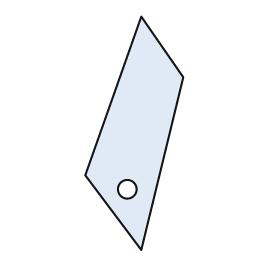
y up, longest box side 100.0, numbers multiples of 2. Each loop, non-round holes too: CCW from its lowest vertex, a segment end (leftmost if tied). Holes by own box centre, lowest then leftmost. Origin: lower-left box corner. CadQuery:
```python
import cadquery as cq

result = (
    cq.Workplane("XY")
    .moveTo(24.0, 0.0)
    .lineTo(42.0, 74.0)
    .lineTo(24.0, 100.0)
    .lineTo(0.0, 32.0)
    .close()
    .moveTo(18.0, 26.0)
    .circle(4.0)
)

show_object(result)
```